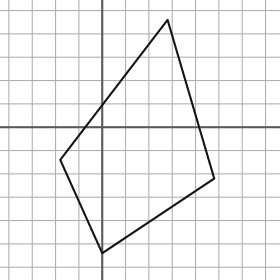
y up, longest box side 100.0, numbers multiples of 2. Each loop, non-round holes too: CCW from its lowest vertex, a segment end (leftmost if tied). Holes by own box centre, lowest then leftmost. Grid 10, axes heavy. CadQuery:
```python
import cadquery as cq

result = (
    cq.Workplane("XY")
    .moveTo(0.0, -54.0)
    .lineTo(48.0, -22.0)
    .lineTo(28.0, 46.0)
    .lineTo(-18.0, -14.0)
    .close()
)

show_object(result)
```